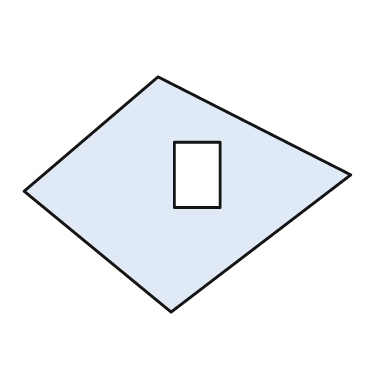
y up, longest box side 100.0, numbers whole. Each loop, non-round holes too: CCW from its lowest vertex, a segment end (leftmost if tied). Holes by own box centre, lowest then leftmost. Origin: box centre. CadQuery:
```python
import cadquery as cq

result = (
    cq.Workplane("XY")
    .moveTo(-5.0, -36.0)
    .lineTo(50.0, 6.0)
    .lineTo(-9.0, 36.0)
    .lineTo(-50.0, 1.0)
    .close()
    .moveTo(-4.0, -4.0)
    .lineTo(10.0, -4.0)
    .lineTo(10.0, 16.0)
    .lineTo(-4.0, 16.0)
    .close()
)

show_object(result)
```